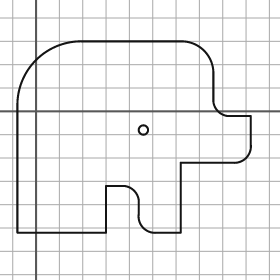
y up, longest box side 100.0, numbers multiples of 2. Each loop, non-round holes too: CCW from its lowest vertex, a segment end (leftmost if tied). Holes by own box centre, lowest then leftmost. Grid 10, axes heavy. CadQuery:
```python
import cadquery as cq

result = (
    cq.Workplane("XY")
    .moveTo(-8.0, -52.0)
    .lineTo(30.0, -52.0)
    .lineTo(30.0, -32.0)
    .lineTo(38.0, -32.0)
    .threePointArc((42.0, -34.0), (44.0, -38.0))
    .lineTo(44.0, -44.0)
    .threePointArc((46.0, -50.0), (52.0, -52.0))
    .lineTo(62.0, -52.0)
    .lineTo(62.0, -22.0)
    .lineTo(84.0, -22.0)
    .threePointArc((90.0, -20.0), (92.0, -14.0))
    .lineTo(92.0, -2.0)
    .lineTo(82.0, -2.0)
    .threePointArc((78.0, 0.0), (76.0, 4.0))
    .lineTo(76.0, 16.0)
    .threePointArc((72.0, 26.0), (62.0, 30.0))
    .lineTo(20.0, 30.0)
    .threePointArc((0.0, 22.0), (-8.0, 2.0))
    .close()
    .moveTo(46.0, -8.0)
    .circle(2.0)
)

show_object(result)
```